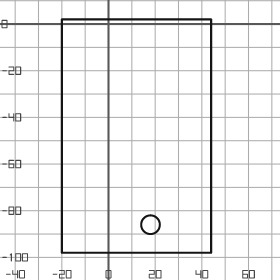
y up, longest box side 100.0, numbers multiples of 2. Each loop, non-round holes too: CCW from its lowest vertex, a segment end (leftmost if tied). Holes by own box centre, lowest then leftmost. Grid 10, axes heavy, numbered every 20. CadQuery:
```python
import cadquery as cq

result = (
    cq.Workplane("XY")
    .moveTo(-20.0, -98.0)
    .lineTo(44.0, -98.0)
    .lineTo(44.0, 2.0)
    .lineTo(-20.0, 2.0)
    .close()
    .moveTo(18.0, -86.0)
    .circle(4.0)
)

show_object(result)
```